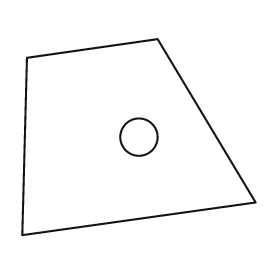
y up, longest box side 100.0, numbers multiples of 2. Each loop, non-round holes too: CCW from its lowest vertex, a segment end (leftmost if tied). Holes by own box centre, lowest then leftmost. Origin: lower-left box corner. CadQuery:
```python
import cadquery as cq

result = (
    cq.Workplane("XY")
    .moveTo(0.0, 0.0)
    .lineTo(100.0, 14.0)
    .lineTo(58.0, 84.0)
    .lineTo(2.0, 76.0)
    .close()
    .moveTo(50.0, 42.0)
    .circle(8.0)
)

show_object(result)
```